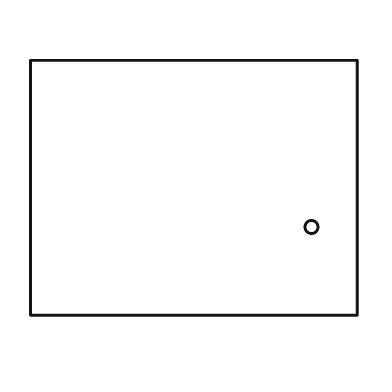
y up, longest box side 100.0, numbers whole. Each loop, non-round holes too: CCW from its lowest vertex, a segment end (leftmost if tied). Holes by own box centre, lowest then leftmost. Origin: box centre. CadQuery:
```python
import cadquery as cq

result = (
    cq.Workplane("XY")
    .moveTo(-50.0, -39.0)
    .lineTo(50.0, -39.0)
    .lineTo(50.0, 39.0)
    .lineTo(-50.0, 39.0)
    .close()
    .moveTo(36.0, -12.0)
    .circle(2.0)
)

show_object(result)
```